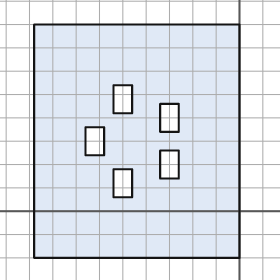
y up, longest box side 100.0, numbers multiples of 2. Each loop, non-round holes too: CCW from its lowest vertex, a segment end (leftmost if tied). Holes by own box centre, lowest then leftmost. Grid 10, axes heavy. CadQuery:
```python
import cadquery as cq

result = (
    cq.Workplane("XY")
    .moveTo(-88.0, -20.0)
    .lineTo(0.0, -20.0)
    .lineTo(0.0, 80.0)
    .lineTo(-88.0, 80.0)
    .close()
    .moveTo(-54.0, 6.0)
    .lineTo(-46.0, 6.0)
    .lineTo(-46.0, 18.0)
    .lineTo(-54.0, 18.0)
    .close()
    .moveTo(-34.0, 14.0)
    .lineTo(-26.0, 14.0)
    .lineTo(-26.0, 26.0)
    .lineTo(-34.0, 26.0)
    .close()
    .moveTo(-66.0, 24.0)
    .lineTo(-58.0, 24.0)
    .lineTo(-58.0, 36.0)
    .lineTo(-66.0, 36.0)
    .close()
    .moveTo(-34.0, 34.0)
    .lineTo(-26.0, 34.0)
    .lineTo(-26.0, 46.0)
    .lineTo(-34.0, 46.0)
    .close()
    .moveTo(-54.0, 42.0)
    .lineTo(-46.0, 42.0)
    .lineTo(-46.0, 54.0)
    .lineTo(-54.0, 54.0)
    .close()
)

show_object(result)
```